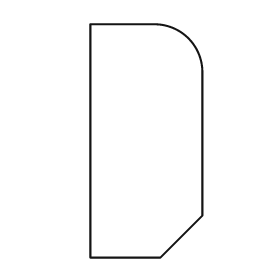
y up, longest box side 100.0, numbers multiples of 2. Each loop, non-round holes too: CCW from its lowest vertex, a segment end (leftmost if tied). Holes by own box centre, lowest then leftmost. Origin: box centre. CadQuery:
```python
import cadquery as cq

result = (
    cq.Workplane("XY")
    .moveTo(-24.0, -50.0)
    .lineTo(6.0, -50.0)
    .lineTo(24.0, -32.0)
    .lineTo(24.0, 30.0)
    .threePointArc((18.0, 44.0), (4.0, 50.0))
    .lineTo(-24.0, 50.0)
    .close()
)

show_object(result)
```